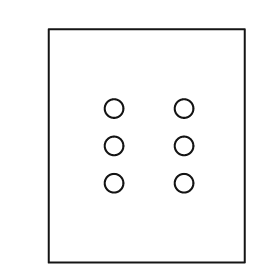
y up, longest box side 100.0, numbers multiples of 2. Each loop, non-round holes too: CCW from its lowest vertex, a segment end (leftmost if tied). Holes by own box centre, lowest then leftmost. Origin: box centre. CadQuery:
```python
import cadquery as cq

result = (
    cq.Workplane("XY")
    .moveTo(-42.0, -50.0)
    .lineTo(42.0, -50.0)
    .lineTo(42.0, 50.0)
    .lineTo(-42.0, 50.0)
    .close()
    .moveTo(-14.0, -16.0)
    .circle(4.0)
    .moveTo(16.0, -16.0)
    .circle(4.0)
    .moveTo(-14.0, 0.0)
    .circle(4.0)
    .moveTo(16.0, 0.0)
    .circle(4.0)
    .moveTo(-14.0, 16.0)
    .circle(4.0)
    .moveTo(16.0, 16.0)
    .circle(4.0)
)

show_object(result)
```